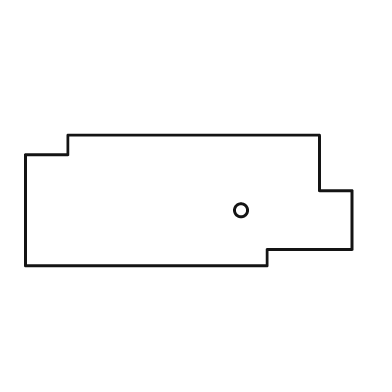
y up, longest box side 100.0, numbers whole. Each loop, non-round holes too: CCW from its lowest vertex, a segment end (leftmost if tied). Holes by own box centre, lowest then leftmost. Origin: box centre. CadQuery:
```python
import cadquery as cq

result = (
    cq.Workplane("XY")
    .moveTo(-50.0, -20.0)
    .lineTo(24.0, -20.0)
    .lineTo(24.0, -15.0)
    .lineTo(50.0, -15.0)
    .lineTo(50.0, 3.0)
    .lineTo(40.0, 3.0)
    .lineTo(40.0, 20.0)
    .lineTo(-37.0, 20.0)
    .lineTo(-37.0, 14.0)
    .lineTo(-50.0, 14.0)
    .close()
    .moveTo(16.0, -3.0)
    .circle(2.0)
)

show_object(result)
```